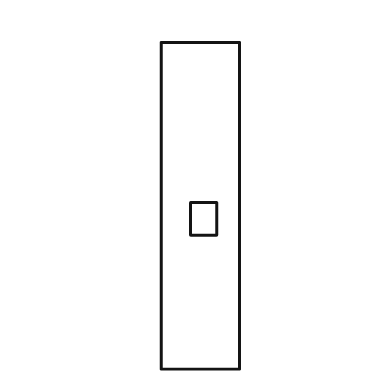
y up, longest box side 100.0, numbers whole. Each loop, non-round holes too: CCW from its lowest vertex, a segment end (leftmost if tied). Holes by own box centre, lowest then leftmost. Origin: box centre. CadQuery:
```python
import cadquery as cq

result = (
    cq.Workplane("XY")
    .moveTo(-12.0, -50.0)
    .lineTo(12.0, -50.0)
    .lineTo(12.0, 50.0)
    .lineTo(-12.0, 50.0)
    .close()
    .moveTo(-3.0, -9.0)
    .lineTo(5.0, -9.0)
    .lineTo(5.0, 1.0)
    .lineTo(-3.0, 1.0)
    .close()
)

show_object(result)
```